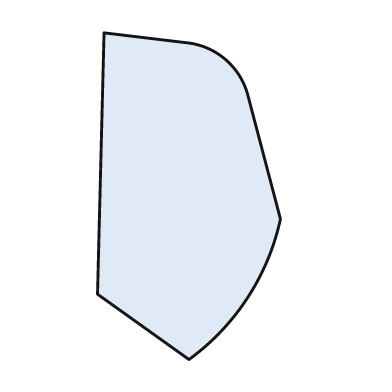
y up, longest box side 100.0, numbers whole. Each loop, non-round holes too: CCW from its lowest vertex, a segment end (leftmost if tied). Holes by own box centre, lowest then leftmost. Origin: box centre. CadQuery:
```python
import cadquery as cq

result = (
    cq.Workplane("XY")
    .moveTo(0.0, -50.0)
    .threePointArc((18.0, -31.0), (28.0, -7.0))
    .lineTo(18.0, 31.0)
    .threePointArc((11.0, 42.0), (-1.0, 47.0))
    .lineTo(-26.0, 50.0)
    .lineTo(-28.0, -30.0)
    .close()
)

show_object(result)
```